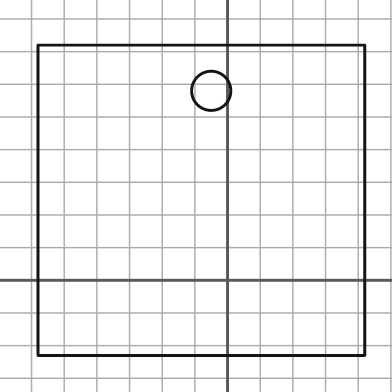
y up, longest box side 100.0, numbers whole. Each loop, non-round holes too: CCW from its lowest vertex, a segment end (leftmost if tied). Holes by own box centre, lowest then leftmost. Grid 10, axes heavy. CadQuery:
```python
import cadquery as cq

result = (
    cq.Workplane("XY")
    .moveTo(-58.0, -23.0)
    .lineTo(42.0, -23.0)
    .lineTo(42.0, 72.0)
    .lineTo(-58.0, 72.0)
    .close()
    .moveTo(-5.0, 58.0)
    .circle(6.0)
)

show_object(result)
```